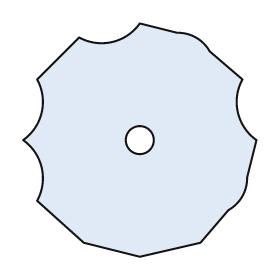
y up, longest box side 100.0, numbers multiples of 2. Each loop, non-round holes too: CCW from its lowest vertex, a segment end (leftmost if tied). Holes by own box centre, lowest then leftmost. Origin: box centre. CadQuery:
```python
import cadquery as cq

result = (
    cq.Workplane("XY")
    .moveTo(0.0, -50.0)
    .lineTo(26.0, -44.0)
    .lineTo(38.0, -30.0)
    .threePointArc((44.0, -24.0), (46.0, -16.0))
    .lineTo(50.0, 0.0)
    .threePointArc((42.0, 12.0), (44.0, 26.0))
    .lineTo(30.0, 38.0)
    .threePointArc((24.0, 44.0), (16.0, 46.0))
    .lineTo(0.0, 50.0)
    .threePointArc((-12.0, 42.0), (-26.0, 44.0))
    .lineTo(-44.0, 26.0)
    .threePointArc((-42.0, 12.0), (-50.0, 0.0))
    .threePointArc((-42.0, -12.0), (-44.0, -26.0))
    .lineTo(-24.0, -44.0)
    .close()
    .moveTo(0.0, 0.0)
    .circle(6.0)
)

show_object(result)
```